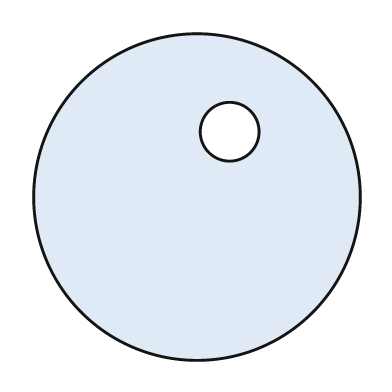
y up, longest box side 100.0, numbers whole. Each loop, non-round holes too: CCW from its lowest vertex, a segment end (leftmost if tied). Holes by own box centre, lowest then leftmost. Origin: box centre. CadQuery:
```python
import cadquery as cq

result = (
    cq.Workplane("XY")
    .moveTo(0.0, 0.0)
    .circle(50.0)
    .moveTo(10.0, 20.0)
    .circle(9.0)
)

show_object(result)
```